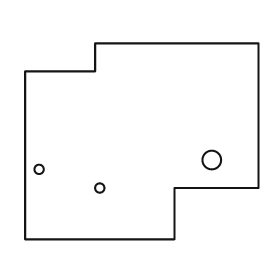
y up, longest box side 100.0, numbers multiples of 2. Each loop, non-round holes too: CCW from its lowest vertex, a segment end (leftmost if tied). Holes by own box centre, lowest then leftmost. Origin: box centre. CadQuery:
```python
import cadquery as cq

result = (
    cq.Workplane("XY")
    .moveTo(-50.0, -42.0)
    .lineTo(14.0, -42.0)
    .lineTo(14.0, -20.0)
    .lineTo(50.0, -20.0)
    .lineTo(50.0, 42.0)
    .lineTo(-20.0, 42.0)
    .lineTo(-20.0, 30.0)
    .lineTo(-50.0, 30.0)
    .close()
    .moveTo(-18.0, -20.0)
    .circle(2.0)
    .moveTo(-44.0, -12.0)
    .circle(2.0)
    .moveTo(30.0, -8.0)
    .circle(4.0)
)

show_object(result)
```